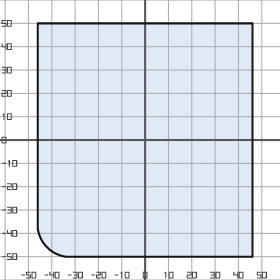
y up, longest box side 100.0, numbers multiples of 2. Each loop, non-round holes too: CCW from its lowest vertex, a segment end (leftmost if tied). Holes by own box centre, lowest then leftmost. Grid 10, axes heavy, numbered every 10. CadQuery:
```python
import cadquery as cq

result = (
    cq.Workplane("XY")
    .moveTo(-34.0, -50.0)
    .lineTo(46.0, -50.0)
    .lineTo(46.0, 50.0)
    .lineTo(-46.0, 50.0)
    .lineTo(-46.0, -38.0)
    .threePointArc((-42.0, -46.0), (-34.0, -50.0))
    .close()
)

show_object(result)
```